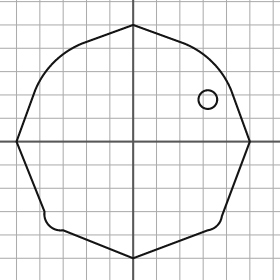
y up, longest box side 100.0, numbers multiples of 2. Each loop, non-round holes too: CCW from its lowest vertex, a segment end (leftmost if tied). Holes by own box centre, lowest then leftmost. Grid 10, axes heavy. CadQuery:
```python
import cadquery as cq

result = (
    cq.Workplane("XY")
    .moveTo(0.0, -50.0)
    .lineTo(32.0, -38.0)
    .threePointArc((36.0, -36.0), (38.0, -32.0))
    .lineTo(50.0, 0.0)
    .lineTo(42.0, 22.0)
    .threePointArc((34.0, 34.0), (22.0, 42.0))
    .lineTo(0.0, 50.0)
    .lineTo(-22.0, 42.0)
    .threePointArc((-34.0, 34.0), (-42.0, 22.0))
    .lineTo(-50.0, 0.0)
    .lineTo(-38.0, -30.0)
    .threePointArc((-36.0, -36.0), (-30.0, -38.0))
    .close()
    .moveTo(32.0, 18.0)
    .circle(4.0)
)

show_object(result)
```